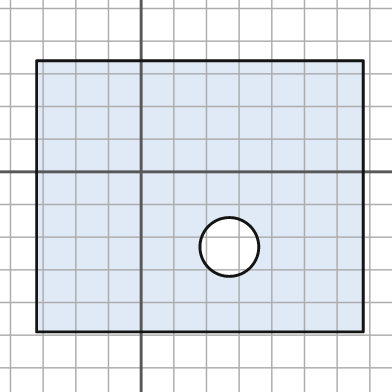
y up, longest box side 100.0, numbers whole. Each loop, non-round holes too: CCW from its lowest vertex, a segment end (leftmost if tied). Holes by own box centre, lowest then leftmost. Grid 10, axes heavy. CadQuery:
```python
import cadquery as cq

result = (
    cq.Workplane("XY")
    .moveTo(-32.0, -49.0)
    .lineTo(68.0, -49.0)
    .lineTo(68.0, 34.0)
    .lineTo(-32.0, 34.0)
    .close()
    .moveTo(27.0, -23.0)
    .circle(9.0)
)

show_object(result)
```